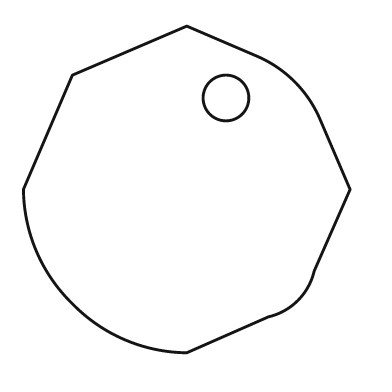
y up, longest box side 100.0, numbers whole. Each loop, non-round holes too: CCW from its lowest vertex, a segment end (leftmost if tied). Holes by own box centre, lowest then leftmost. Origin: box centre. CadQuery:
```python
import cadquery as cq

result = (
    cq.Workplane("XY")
    .moveTo(0.0, -50.0)
    .lineTo(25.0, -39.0)
    .threePointArc((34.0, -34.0), (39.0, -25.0))
    .lineTo(50.0, 0.0)
    .lineTo(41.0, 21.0)
    .threePointArc((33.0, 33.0), (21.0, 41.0))
    .lineTo(0.0, 50.0)
    .lineTo(-35.0, 35.0)
    .lineTo(-50.0, 0.0)
    .threePointArc((-46.0, -19.0), (-35.0, -35.0))
    .threePointArc((-19.0, -46.0), (0.0, -50.0))
    .close()
    .moveTo(12.0, 28.0)
    .circle(7.0)
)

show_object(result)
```